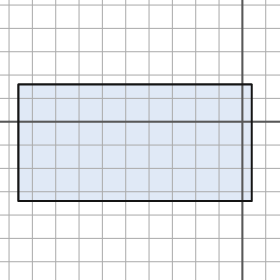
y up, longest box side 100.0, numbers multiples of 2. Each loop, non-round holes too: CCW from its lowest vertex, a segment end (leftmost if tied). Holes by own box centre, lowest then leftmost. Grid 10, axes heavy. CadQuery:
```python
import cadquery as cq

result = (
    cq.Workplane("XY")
    .moveTo(-96.0, -34.0)
    .lineTo(4.0, -34.0)
    .lineTo(4.0, 16.0)
    .lineTo(-96.0, 16.0)
    .close()
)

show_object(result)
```